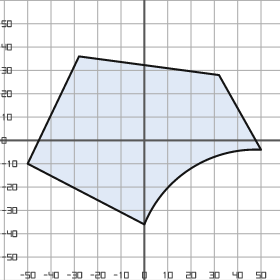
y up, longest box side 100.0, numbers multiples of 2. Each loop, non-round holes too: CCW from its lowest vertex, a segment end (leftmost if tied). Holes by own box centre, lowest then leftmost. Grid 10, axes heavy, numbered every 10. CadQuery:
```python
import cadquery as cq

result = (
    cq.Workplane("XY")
    .moveTo(0.0, -36.0)
    .threePointArc((20.0, -12.0), (50.0, -4.0))
    .lineTo(32.0, 28.0)
    .lineTo(-28.0, 36.0)
    .lineTo(-50.0, -10.0)
    .close()
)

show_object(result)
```